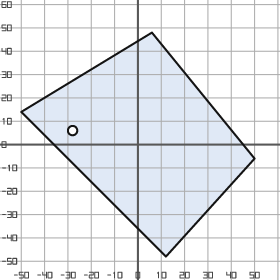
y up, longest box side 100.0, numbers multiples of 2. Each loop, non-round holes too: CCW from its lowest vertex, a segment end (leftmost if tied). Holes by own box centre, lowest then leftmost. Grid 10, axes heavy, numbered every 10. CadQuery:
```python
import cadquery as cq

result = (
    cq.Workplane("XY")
    .moveTo(12.0, -48.0)
    .lineTo(50.0, -6.0)
    .lineTo(6.0, 48.0)
    .lineTo(-50.0, 14.0)
    .close()
    .moveTo(-28.0, 6.0)
    .circle(2.0)
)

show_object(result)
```